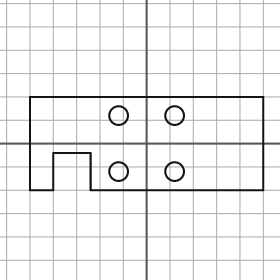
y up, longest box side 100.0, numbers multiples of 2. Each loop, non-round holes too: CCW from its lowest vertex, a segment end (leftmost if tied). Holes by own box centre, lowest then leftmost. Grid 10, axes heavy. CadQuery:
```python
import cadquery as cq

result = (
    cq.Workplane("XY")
    .moveTo(-50.0, -20.0)
    .lineTo(-40.0, -20.0)
    .lineTo(-40.0, -4.0)
    .lineTo(-24.0, -4.0)
    .lineTo(-24.0, -20.0)
    .lineTo(50.0, -20.0)
    .lineTo(50.0, 20.0)
    .lineTo(-50.0, 20.0)
    .close()
    .moveTo(-12.0, -12.0)
    .circle(4.0)
    .moveTo(12.0, -12.0)
    .circle(4.0)
    .moveTo(-12.0, 12.0)
    .circle(4.0)
    .moveTo(12.0, 12.0)
    .circle(4.0)
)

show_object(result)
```